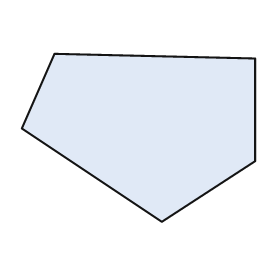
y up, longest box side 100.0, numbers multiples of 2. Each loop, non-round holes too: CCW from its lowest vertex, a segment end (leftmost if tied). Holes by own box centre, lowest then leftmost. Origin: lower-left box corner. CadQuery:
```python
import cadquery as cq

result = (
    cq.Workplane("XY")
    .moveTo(60.0, 0.0)
    .lineTo(100.0, 26.0)
    .lineTo(100.0, 70.0)
    .lineTo(14.0, 72.0)
    .lineTo(0.0, 40.0)
    .close()
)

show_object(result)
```